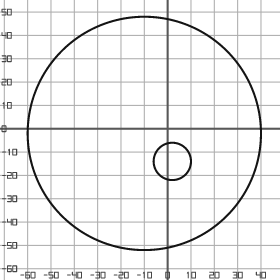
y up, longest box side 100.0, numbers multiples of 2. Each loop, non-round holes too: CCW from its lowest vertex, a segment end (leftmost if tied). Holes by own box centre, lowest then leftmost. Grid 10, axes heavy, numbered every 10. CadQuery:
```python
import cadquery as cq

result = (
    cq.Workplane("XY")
    .moveTo(-10.0, -2.0)
    .circle(50.0)
    .moveTo(2.0, -14.0)
    .circle(8.0)
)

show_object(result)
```